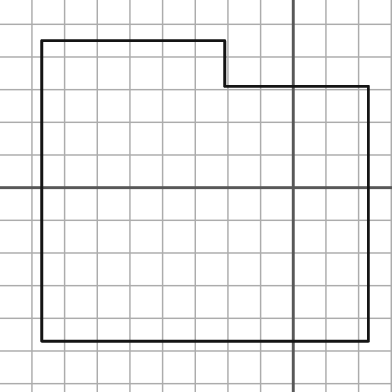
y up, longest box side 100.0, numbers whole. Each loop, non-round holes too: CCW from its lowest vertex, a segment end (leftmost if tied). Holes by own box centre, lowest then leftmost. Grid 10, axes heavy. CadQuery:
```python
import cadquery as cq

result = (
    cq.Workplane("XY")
    .moveTo(-77.0, -47.0)
    .lineTo(23.0, -47.0)
    .lineTo(23.0, 31.0)
    .lineTo(-21.0, 31.0)
    .lineTo(-21.0, 45.0)
    .lineTo(-77.0, 45.0)
    .close()
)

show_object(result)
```